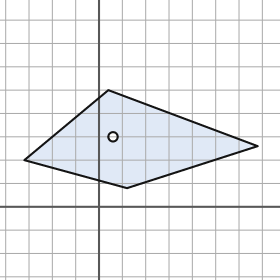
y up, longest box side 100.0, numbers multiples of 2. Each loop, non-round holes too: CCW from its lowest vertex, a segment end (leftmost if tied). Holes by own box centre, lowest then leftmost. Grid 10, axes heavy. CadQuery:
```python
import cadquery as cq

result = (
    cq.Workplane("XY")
    .moveTo(12.0, 8.0)
    .lineTo(68.0, 26.0)
    .lineTo(4.0, 50.0)
    .lineTo(-32.0, 20.0)
    .close()
    .moveTo(6.0, 30.0)
    .circle(2.0)
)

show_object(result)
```